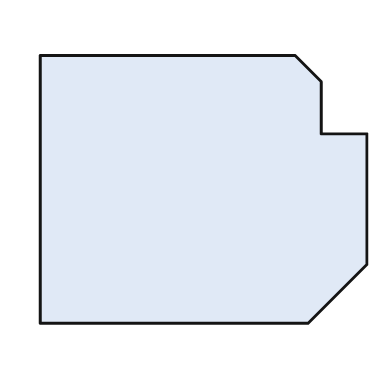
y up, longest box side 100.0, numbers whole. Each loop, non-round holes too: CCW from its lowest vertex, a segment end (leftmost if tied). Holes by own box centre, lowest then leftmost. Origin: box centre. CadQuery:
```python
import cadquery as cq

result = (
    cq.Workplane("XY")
    .moveTo(-50.0, -41.0)
    .lineTo(32.0, -41.0)
    .lineTo(50.0, -23.0)
    .lineTo(50.0, 17.0)
    .lineTo(36.0, 17.0)
    .lineTo(36.0, 33.0)
    .lineTo(28.0, 41.0)
    .lineTo(-50.0, 41.0)
    .close()
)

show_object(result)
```